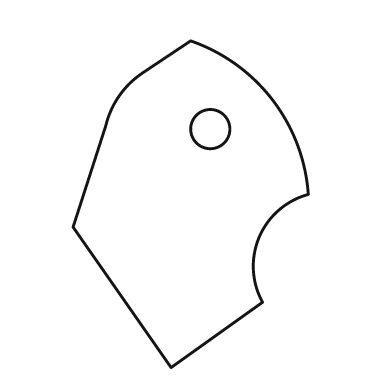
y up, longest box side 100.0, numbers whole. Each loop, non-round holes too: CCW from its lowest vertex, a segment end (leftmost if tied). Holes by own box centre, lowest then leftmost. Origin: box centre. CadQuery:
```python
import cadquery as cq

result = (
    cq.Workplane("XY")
    .moveTo(-6.0, -50.0)
    .lineTo(22.0, -30.0)
    .threePointArc((21.0, -10.0), (36.0, 3.0))
    .threePointArc((25.0, 32.0), (0.0, 50.0))
    .lineTo(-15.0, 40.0)
    .threePointArc((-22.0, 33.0), (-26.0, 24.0))
    .lineTo(-36.0, -7.0)
    .close()
    .moveTo(6.0, 23.0)
    .circle(6.0)
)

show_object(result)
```